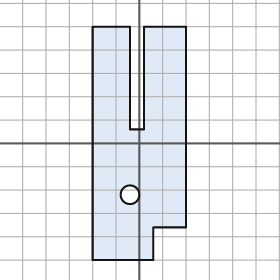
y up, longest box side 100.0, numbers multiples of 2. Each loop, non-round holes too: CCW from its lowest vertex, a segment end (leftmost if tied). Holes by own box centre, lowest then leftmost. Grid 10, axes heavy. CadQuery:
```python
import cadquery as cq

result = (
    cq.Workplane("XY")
    .moveTo(-20.0, -50.0)
    .lineTo(6.0, -50.0)
    .lineTo(6.0, -36.0)
    .lineTo(20.0, -36.0)
    .lineTo(20.0, 50.0)
    .lineTo(2.0, 50.0)
    .lineTo(2.0, 6.0)
    .lineTo(-4.0, 6.0)
    .lineTo(-4.0, 50.0)
    .lineTo(-20.0, 50.0)
    .close()
    .moveTo(-4.0, -22.0)
    .circle(4.0)
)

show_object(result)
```